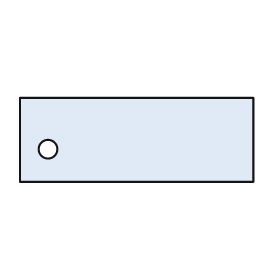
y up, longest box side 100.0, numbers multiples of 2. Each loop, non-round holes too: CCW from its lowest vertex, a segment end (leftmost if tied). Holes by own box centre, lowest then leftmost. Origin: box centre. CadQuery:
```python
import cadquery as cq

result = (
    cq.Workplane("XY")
    .moveTo(-50.0, -18.0)
    .lineTo(50.0, -18.0)
    .lineTo(50.0, 18.0)
    .lineTo(-50.0, 18.0)
    .close()
    .moveTo(-38.0, -4.0)
    .circle(4.0)
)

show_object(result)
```